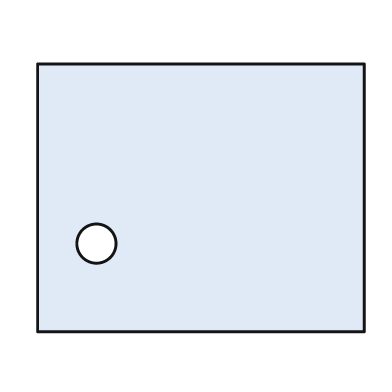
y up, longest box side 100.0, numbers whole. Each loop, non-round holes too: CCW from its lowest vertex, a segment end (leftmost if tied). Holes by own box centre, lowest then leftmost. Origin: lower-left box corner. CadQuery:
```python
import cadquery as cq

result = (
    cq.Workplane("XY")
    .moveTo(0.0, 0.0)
    .lineTo(100.0, 0.0)
    .lineTo(100.0, 82.0)
    .lineTo(0.0, 82.0)
    .close()
    .moveTo(18.0, 27.0)
    .circle(6.0)
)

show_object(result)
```